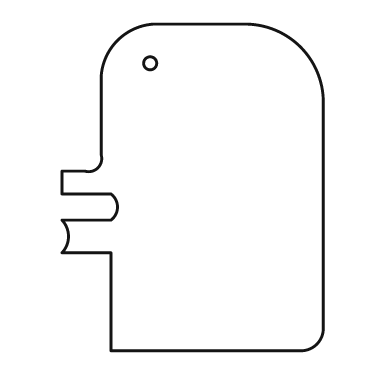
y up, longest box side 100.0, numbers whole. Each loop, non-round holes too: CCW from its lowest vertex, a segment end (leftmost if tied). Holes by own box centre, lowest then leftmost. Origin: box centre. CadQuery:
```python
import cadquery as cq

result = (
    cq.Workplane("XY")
    .moveTo(-25.0, -50.0)
    .lineTo(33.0, -50.0)
    .threePointArc((38.0, -48.0), (40.0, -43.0))
    .lineTo(40.0, 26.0)
    .threePointArc((33.0, 43.0), (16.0, 50.0))
    .lineTo(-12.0, 50.0)
    .threePointArc((-23.0, 45.0), (-28.0, 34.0))
    .lineTo(-28.0, 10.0)
    .threePointArc((-29.0, 6.0), (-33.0, 5.0))
    .lineTo(-40.0, 5.0)
    .lineTo(-40.0, -2.0)
    .lineTo(-25.0, -2.0)
    .threePointArc((-23.0, -6.0), (-25.0, -10.0))
    .lineTo(-40.0, -10.0)
    .threePointArc((-38.0, -15.0), (-40.0, -20.0))
    .lineTo(-25.0, -20.0)
    .close()
    .moveTo(-13.0, 38.0)
    .circle(2.0)
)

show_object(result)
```